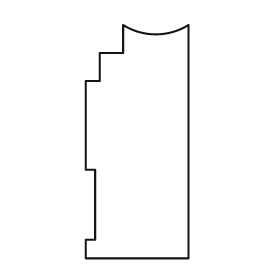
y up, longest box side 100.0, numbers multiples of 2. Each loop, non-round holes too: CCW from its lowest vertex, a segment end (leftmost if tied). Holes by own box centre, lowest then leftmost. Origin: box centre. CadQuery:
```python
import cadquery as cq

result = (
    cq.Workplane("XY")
    .moveTo(-22.0, -50.0)
    .lineTo(22.0, -50.0)
    .lineTo(22.0, 50.0)
    .threePointArc((8.0, 46.0), (-6.0, 50.0))
    .lineTo(-6.0, 38.0)
    .lineTo(-16.0, 38.0)
    .lineTo(-16.0, 26.0)
    .lineTo(-22.0, 26.0)
    .lineTo(-22.0, -12.0)
    .lineTo(-18.0, -12.0)
    .lineTo(-18.0, -42.0)
    .lineTo(-22.0, -42.0)
    .close()
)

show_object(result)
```